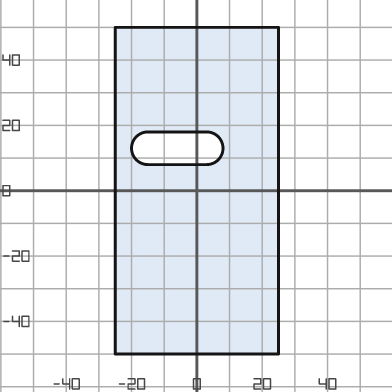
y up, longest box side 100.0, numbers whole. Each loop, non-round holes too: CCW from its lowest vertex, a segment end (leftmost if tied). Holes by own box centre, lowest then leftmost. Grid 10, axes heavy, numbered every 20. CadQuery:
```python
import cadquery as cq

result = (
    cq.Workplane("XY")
    .moveTo(-25.0, -50.0)
    .lineTo(25.0, -50.0)
    .lineTo(25.0, 50.0)
    .lineTo(-25.0, 50.0)
    .close()
    .moveTo(-15.0, 8.0)
    .lineTo(3.0, 8.0)
    .threePointArc((8.0, 13.0), (3.0, 18.0))
    .lineTo(-15.0, 18.0)
    .threePointArc((-20.0, 13.0), (-15.0, 8.0))
    .close()
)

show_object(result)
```